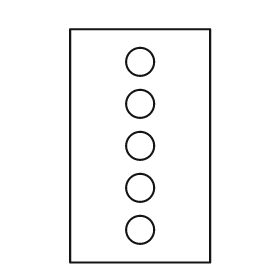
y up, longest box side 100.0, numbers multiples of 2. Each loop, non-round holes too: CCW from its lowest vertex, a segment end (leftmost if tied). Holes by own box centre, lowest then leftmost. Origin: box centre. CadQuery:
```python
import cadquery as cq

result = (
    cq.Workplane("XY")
    .moveTo(-30.0, -50.0)
    .lineTo(30.0, -50.0)
    .lineTo(30.0, 50.0)
    .lineTo(-30.0, 50.0)
    .close()
    .moveTo(0.0, -36.0)
    .circle(6.0)
    .moveTo(0.0, -18.0)
    .circle(6.0)
    .moveTo(0.0, 0.0)
    .circle(6.0)
    .moveTo(0.0, 18.0)
    .circle(6.0)
    .moveTo(0.0, 36.0)
    .circle(6.0)
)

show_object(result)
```